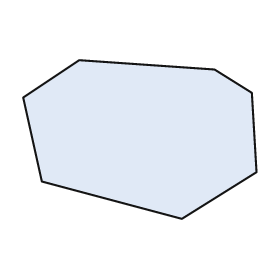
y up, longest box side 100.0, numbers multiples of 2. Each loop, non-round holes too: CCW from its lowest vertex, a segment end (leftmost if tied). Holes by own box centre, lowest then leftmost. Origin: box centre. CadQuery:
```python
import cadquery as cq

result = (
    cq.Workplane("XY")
    .moveTo(18.0, -34.0)
    .lineTo(50.0, -14.0)
    .lineTo(48.0, 20.0)
    .lineTo(32.0, 30.0)
    .lineTo(-26.0, 34.0)
    .lineTo(-50.0, 18.0)
    .lineTo(-42.0, -18.0)
    .close()
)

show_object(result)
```